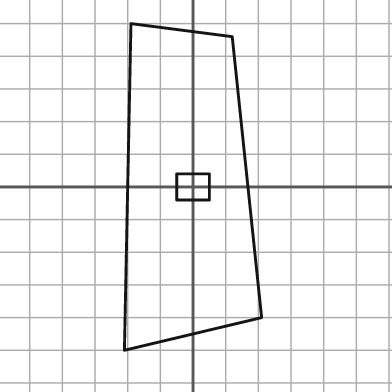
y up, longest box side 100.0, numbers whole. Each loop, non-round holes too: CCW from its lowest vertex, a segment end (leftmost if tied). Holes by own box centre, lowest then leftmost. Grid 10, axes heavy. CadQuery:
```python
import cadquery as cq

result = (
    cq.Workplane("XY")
    .moveTo(-21.0, -50.0)
    .lineTo(21.0, -40.0)
    .lineTo(12.0, 46.0)
    .lineTo(-19.0, 50.0)
    .close()
    .moveTo(-5.0, -4.0)
    .lineTo(5.0, -4.0)
    .lineTo(5.0, 4.0)
    .lineTo(-5.0, 4.0)
    .close()
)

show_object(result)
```